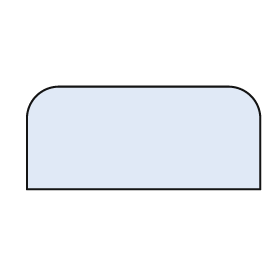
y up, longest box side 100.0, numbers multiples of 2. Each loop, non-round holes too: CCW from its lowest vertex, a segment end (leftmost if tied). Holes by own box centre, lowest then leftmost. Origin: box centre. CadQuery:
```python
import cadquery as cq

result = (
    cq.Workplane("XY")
    .moveTo(-50.0, -22.0)
    .lineTo(50.0, -22.0)
    .lineTo(50.0, 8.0)
    .threePointArc((46.0, 18.0), (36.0, 22.0))
    .lineTo(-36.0, 22.0)
    .threePointArc((-46.0, 18.0), (-50.0, 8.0))
    .close()
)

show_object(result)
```